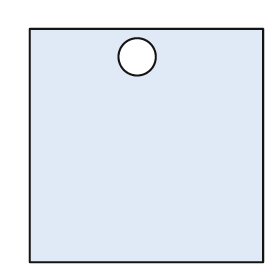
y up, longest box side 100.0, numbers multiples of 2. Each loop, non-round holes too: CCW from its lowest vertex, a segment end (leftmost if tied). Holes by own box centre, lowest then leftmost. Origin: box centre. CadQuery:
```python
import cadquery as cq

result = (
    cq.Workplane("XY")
    .moveTo(-50.0, -50.0)
    .lineTo(50.0, -50.0)
    .lineTo(50.0, 50.0)
    .lineTo(-50.0, 50.0)
    .close()
    .moveTo(-4.0, 38.0)
    .circle(8.0)
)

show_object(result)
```